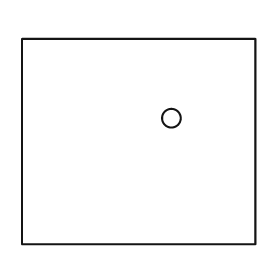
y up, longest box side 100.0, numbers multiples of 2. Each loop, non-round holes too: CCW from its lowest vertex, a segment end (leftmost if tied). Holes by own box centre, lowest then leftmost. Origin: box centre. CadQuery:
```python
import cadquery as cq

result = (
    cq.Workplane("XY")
    .moveTo(-50.0, -44.0)
    .lineTo(50.0, -44.0)
    .lineTo(50.0, 44.0)
    .lineTo(-50.0, 44.0)
    .close()
    .moveTo(14.0, 10.0)
    .circle(4.0)
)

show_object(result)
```